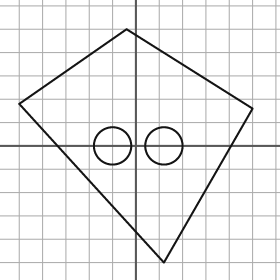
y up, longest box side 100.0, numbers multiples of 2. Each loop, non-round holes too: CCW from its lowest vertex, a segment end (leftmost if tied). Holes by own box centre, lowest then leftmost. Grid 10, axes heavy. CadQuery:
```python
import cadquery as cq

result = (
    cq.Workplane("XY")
    .moveTo(12.0, -50.0)
    .lineTo(50.0, 16.0)
    .lineTo(-4.0, 50.0)
    .lineTo(-50.0, 18.0)
    .close()
    .moveTo(-10.0, 0.0)
    .circle(8.0)
    .moveTo(12.0, 0.0)
    .circle(8.0)
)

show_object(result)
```